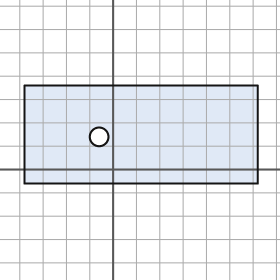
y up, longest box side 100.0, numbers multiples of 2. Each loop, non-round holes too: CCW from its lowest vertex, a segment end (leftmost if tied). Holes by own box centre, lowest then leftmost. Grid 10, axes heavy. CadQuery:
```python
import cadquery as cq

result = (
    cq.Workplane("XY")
    .moveTo(-38.0, -6.0)
    .lineTo(62.0, -6.0)
    .lineTo(62.0, 36.0)
    .lineTo(-38.0, 36.0)
    .close()
    .moveTo(-6.0, 14.0)
    .circle(4.0)
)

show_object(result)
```